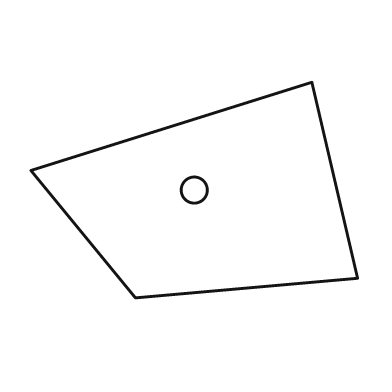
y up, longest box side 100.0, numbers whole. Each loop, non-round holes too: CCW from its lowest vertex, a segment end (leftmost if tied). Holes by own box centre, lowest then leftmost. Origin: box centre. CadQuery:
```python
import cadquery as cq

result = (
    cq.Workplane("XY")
    .moveTo(-18.0, -33.0)
    .lineTo(50.0, -27.0)
    .lineTo(36.0, 33.0)
    .lineTo(-50.0, 6.0)
    .close()
    .moveTo(0.0, 0.0)
    .circle(4.0)
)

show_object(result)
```